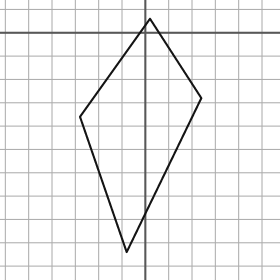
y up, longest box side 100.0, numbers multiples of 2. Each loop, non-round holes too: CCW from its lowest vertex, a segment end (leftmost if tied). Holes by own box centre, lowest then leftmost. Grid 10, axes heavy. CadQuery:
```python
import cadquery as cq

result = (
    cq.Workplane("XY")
    .moveTo(-8.0, -94.0)
    .lineTo(24.0, -28.0)
    .lineTo(2.0, 6.0)
    .lineTo(-28.0, -36.0)
    .close()
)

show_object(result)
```